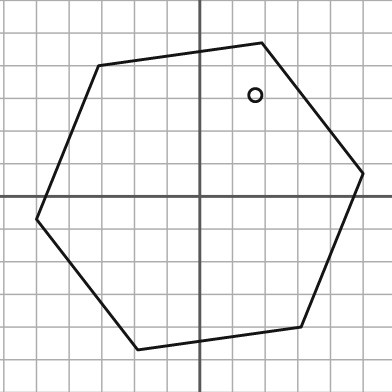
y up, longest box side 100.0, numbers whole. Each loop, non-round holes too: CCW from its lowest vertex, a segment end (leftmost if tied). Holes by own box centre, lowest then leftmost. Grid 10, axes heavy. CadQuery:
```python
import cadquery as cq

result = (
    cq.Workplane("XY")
    .moveTo(-19.0, -47.0)
    .lineTo(31.0, -40.0)
    .lineTo(50.0, 7.0)
    .lineTo(19.0, 47.0)
    .lineTo(-31.0, 40.0)
    .lineTo(-50.0, -7.0)
    .close()
    .moveTo(17.0, 31.0)
    .circle(2.0)
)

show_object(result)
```